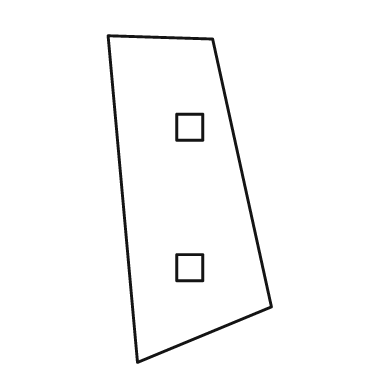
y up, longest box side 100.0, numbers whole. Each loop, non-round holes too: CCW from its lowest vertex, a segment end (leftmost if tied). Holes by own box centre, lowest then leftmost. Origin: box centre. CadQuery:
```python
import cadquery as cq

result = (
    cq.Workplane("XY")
    .moveTo(-16.0, -50.0)
    .lineTo(25.0, -33.0)
    .lineTo(7.0, 49.0)
    .lineTo(-25.0, 50.0)
    .close()
    .moveTo(-4.0, -25.0)
    .lineTo(4.0, -25.0)
    .lineTo(4.0, -17.0)
    .lineTo(-4.0, -17.0)
    .close()
    .moveTo(-4.0, 18.0)
    .lineTo(4.0, 18.0)
    .lineTo(4.0, 26.0)
    .lineTo(-4.0, 26.0)
    .close()
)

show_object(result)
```